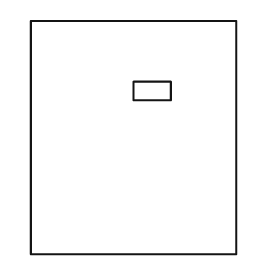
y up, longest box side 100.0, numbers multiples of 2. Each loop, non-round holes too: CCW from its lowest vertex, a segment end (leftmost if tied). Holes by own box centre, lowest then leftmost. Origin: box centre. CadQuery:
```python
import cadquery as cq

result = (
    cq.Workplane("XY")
    .moveTo(-44.0, -50.0)
    .lineTo(44.0, -50.0)
    .lineTo(44.0, 50.0)
    .lineTo(-44.0, 50.0)
    .close()
    .moveTo(0.0, 16.0)
    .lineTo(16.0, 16.0)
    .lineTo(16.0, 24.0)
    .lineTo(0.0, 24.0)
    .close()
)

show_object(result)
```